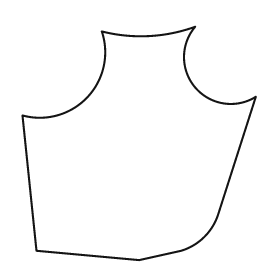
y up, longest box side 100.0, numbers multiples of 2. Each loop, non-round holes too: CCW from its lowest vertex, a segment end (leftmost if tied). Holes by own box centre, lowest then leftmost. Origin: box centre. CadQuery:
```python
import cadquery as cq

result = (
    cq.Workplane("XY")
    .moveTo(0.0, -50.0)
    .lineTo(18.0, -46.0)
    .threePointArc((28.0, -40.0), (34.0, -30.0))
    .lineTo(50.0, 20.0)
    .threePointArc((24.0, 24.0), (24.0, 50.0))
    .threePointArc((4.0, 46.0), (-16.0, 48.0))
    .threePointArc((-22.0, 20.0), (-50.0, 12.0))
    .lineTo(-44.0, -46.0)
    .close()
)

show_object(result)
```